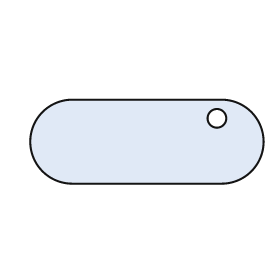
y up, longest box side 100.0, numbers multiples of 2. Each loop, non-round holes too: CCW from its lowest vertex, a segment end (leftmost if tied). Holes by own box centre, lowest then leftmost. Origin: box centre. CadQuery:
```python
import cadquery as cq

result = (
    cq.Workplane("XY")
    .moveTo(-32.0, -18.0)
    .lineTo(32.0, -18.0)
    .threePointArc((50.0, 0.0), (32.0, 18.0))
    .lineTo(-32.0, 18.0)
    .threePointArc((-50.0, 0.0), (-32.0, -18.0))
    .close()
    .moveTo(30.0, 10.0)
    .circle(4.0)
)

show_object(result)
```